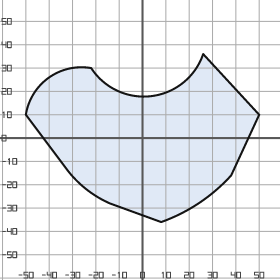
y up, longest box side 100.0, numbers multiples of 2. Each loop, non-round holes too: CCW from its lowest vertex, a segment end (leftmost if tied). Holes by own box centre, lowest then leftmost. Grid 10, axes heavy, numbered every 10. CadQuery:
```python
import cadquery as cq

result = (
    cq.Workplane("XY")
    .moveTo(8.0, -36.0)
    .threePointArc((24.0, -28.0), (38.0, -16.0))
    .lineTo(50.0, 10.0)
    .lineTo(26.0, 36.0)
    .threePointArc((4.0, 18.0), (-22.0, 30.0))
    .threePointArc((-40.0, 26.0), (-50.0, 10.0))
    .lineTo(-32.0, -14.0)
    .threePointArc((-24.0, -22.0), (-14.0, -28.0))
    .close()
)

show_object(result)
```